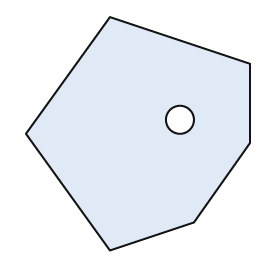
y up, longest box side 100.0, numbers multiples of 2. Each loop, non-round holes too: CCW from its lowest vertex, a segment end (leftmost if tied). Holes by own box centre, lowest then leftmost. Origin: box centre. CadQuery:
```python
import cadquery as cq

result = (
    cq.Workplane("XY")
    .moveTo(-12.0, -50.0)
    .lineTo(24.0, -38.0)
    .lineTo(48.0, -4.0)
    .lineTo(48.0, 30.0)
    .lineTo(-12.0, 50.0)
    .lineTo(-48.0, 0.0)
    .close()
    .moveTo(18.0, 6.0)
    .circle(6.0)
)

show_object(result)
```